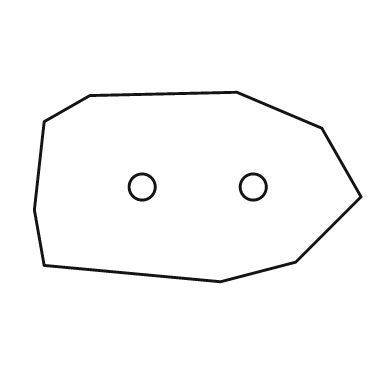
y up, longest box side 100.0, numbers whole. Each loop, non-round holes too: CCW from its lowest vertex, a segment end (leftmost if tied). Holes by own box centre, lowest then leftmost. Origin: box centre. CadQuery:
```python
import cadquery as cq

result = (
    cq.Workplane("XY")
    .moveTo(7.0, -29.0)
    .lineTo(30.0, -23.0)
    .lineTo(50.0, -3.0)
    .lineTo(38.0, 18.0)
    .lineTo(12.0, 29.0)
    .lineTo(-33.0, 28.0)
    .lineTo(-47.0, 20.0)
    .lineTo(-50.0, -7.0)
    .lineTo(-47.0, -24.0)
    .close()
    .moveTo(-17.0, 0.0)
    .circle(4.0)
    .moveTo(17.0, 0.0)
    .circle(4.0)
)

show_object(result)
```